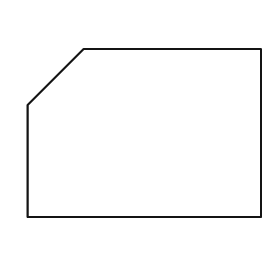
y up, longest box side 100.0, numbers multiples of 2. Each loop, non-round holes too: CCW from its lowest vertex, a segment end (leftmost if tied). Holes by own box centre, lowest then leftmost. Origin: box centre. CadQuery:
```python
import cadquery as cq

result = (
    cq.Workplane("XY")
    .moveTo(-50.0, -36.0)
    .lineTo(50.0, -36.0)
    .lineTo(50.0, 36.0)
    .lineTo(-26.0, 36.0)
    .lineTo(-50.0, 12.0)
    .close()
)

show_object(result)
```